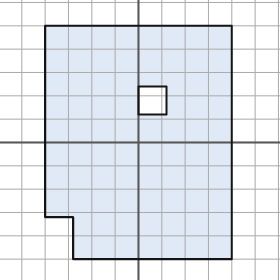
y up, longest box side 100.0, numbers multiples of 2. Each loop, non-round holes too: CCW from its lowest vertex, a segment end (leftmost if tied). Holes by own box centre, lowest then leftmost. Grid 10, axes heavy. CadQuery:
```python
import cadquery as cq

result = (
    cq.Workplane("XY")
    .moveTo(-28.0, -50.0)
    .lineTo(40.0, -50.0)
    .lineTo(40.0, 50.0)
    .lineTo(-40.0, 50.0)
    .lineTo(-40.0, -32.0)
    .lineTo(-28.0, -32.0)
    .close()
    .moveTo(0.0, 12.0)
    .lineTo(12.0, 12.0)
    .lineTo(12.0, 24.0)
    .lineTo(0.0, 24.0)
    .close()
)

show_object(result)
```